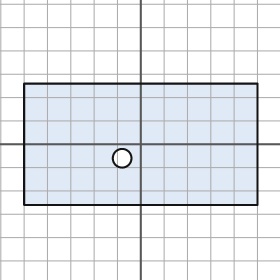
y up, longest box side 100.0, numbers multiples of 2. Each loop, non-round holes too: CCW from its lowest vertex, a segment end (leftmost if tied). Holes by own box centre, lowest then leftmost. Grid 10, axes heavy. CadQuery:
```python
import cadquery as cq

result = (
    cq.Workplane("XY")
    .moveTo(-50.0, -26.0)
    .lineTo(50.0, -26.0)
    .lineTo(50.0, 26.0)
    .lineTo(-50.0, 26.0)
    .close()
    .moveTo(-8.0, -6.0)
    .circle(4.0)
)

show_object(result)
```